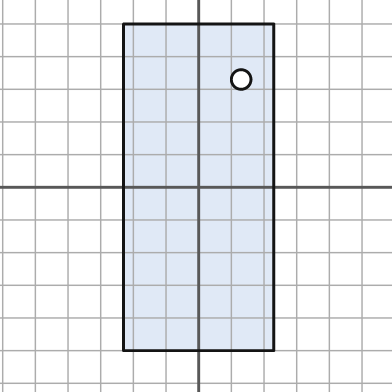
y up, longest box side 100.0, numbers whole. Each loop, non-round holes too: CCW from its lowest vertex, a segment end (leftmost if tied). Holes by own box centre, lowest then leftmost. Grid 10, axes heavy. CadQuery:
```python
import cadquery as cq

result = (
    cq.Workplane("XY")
    .moveTo(-23.0, -50.0)
    .lineTo(23.0, -50.0)
    .lineTo(23.0, 50.0)
    .lineTo(-23.0, 50.0)
    .close()
    .moveTo(13.0, 33.0)
    .circle(3.0)
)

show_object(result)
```